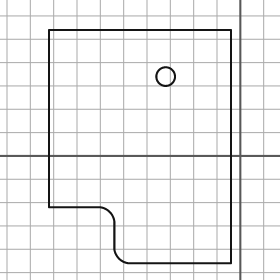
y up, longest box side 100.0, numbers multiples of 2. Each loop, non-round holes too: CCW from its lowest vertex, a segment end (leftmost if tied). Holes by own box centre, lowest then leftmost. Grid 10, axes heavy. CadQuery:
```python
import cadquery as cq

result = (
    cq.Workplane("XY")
    .moveTo(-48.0, -46.0)
    .lineTo(-4.0, -46.0)
    .lineTo(-4.0, 54.0)
    .lineTo(-82.0, 54.0)
    .lineTo(-82.0, -22.0)
    .lineTo(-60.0, -22.0)
    .threePointArc((-56.0, -24.0), (-54.0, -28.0))
    .lineTo(-54.0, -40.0)
    .threePointArc((-52.0, -44.0), (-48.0, -46.0))
    .close()
    .moveTo(-32.0, 34.0)
    .circle(4.0)
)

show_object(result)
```